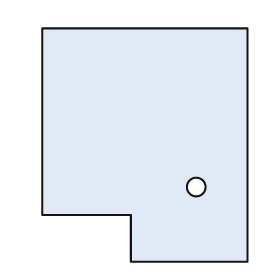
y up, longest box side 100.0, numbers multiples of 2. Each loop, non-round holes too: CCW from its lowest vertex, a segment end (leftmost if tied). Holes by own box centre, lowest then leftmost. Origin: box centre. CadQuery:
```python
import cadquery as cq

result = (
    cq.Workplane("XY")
    .moveTo(-6.0, -50.0)
    .lineTo(44.0, -50.0)
    .lineTo(44.0, 50.0)
    .lineTo(-44.0, 50.0)
    .lineTo(-44.0, -30.0)
    .lineTo(-6.0, -30.0)
    .close()
    .moveTo(22.0, -18.0)
    .circle(4.0)
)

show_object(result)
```